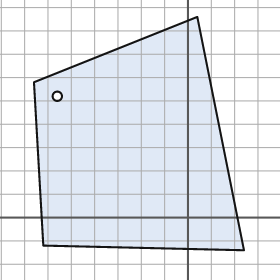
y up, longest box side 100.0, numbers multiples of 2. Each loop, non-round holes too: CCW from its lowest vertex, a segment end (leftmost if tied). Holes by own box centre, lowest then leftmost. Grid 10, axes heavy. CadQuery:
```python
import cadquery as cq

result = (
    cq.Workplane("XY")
    .moveTo(24.0, -14.0)
    .lineTo(4.0, 86.0)
    .lineTo(-66.0, 58.0)
    .lineTo(-62.0, -12.0)
    .close()
    .moveTo(-56.0, 52.0)
    .circle(2.0)
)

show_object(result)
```